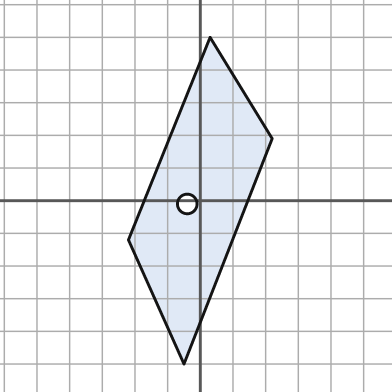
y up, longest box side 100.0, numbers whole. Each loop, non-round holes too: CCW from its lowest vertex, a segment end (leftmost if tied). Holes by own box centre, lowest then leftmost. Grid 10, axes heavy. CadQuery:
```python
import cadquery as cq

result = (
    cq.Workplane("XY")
    .moveTo(-5.0, -50.0)
    .lineTo(22.0, 19.0)
    .lineTo(3.0, 50.0)
    .lineTo(-22.0, -12.0)
    .close()
    .moveTo(-4.0, -1.0)
    .circle(3.0)
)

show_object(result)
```